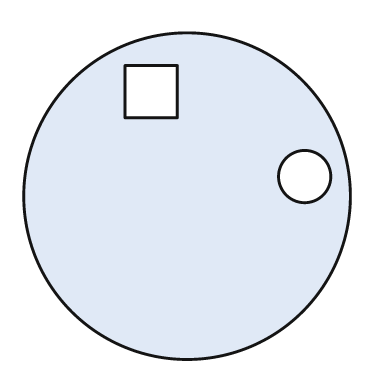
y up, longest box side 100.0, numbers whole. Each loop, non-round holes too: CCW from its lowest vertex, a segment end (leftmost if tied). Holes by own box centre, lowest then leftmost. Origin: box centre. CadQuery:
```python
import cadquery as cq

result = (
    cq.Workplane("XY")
    .moveTo(0.0, 0.0)
    .circle(50.0)
    .moveTo(36.0, 6.0)
    .circle(8.0)
    .moveTo(-19.0, 24.0)
    .lineTo(-3.0, 24.0)
    .lineTo(-3.0, 40.0)
    .lineTo(-19.0, 40.0)
    .close()
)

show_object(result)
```